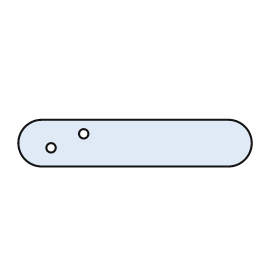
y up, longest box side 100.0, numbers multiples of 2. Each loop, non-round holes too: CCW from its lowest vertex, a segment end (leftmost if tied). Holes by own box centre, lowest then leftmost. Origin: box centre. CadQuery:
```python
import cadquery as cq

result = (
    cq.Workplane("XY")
    .moveTo(-40.0, -10.0)
    .lineTo(40.0, -10.0)
    .threePointArc((50.0, 0.0), (40.0, 10.0))
    .lineTo(-40.0, 10.0)
    .threePointArc((-50.0, 0.0), (-40.0, -10.0))
    .close()
    .moveTo(-36.0, -2.0)
    .circle(2.0)
    .moveTo(-22.0, 4.0)
    .circle(2.0)
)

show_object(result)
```